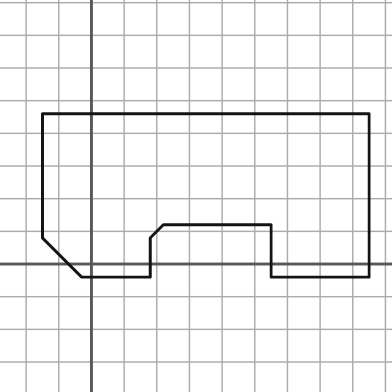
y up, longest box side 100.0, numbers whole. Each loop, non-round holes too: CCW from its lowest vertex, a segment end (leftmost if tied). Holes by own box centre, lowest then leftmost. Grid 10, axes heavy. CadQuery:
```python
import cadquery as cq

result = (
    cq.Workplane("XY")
    .moveTo(-3.0, -4.0)
    .lineTo(18.0, -4.0)
    .lineTo(18.0, 8.0)
    .lineTo(22.0, 12.0)
    .lineTo(55.0, 12.0)
    .lineTo(55.0, -4.0)
    .lineTo(85.0, -4.0)
    .lineTo(85.0, 46.0)
    .lineTo(-15.0, 46.0)
    .lineTo(-15.0, 8.0)
    .close()
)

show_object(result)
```